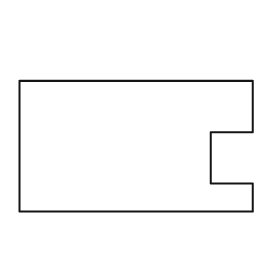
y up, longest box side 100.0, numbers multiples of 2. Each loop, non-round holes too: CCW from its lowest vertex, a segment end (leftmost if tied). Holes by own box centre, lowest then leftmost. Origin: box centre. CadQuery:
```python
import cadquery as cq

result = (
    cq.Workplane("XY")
    .moveTo(-50.0, -28.0)
    .lineTo(50.0, -28.0)
    .lineTo(50.0, -16.0)
    .lineTo(32.0, -16.0)
    .lineTo(32.0, 6.0)
    .lineTo(50.0, 6.0)
    .lineTo(50.0, 28.0)
    .lineTo(-50.0, 28.0)
    .close()
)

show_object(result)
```